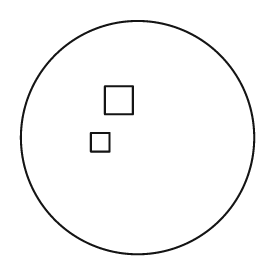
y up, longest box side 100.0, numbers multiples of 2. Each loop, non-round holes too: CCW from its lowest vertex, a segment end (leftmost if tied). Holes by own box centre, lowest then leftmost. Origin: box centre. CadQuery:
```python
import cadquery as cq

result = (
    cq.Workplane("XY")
    .moveTo(0.0, 0.0)
    .circle(50.0)
    .moveTo(-20.0, -6.0)
    .lineTo(-12.0, -6.0)
    .lineTo(-12.0, 2.0)
    .lineTo(-20.0, 2.0)
    .close()
    .moveTo(-14.0, 10.0)
    .lineTo(-2.0, 10.0)
    .lineTo(-2.0, 22.0)
    .lineTo(-14.0, 22.0)
    .close()
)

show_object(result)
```